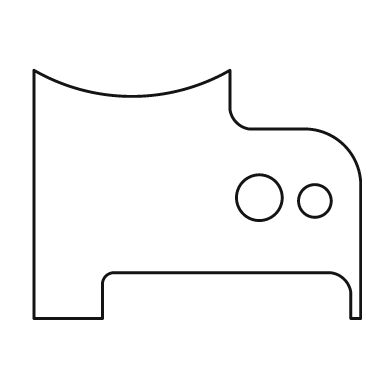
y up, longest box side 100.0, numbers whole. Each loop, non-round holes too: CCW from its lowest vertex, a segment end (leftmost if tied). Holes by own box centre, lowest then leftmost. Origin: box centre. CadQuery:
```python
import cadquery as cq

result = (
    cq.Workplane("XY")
    .moveTo(-50.0, -38.0)
    .lineTo(-29.0, -38.0)
    .lineTo(-29.0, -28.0)
    .threePointArc((-28.0, -25.0), (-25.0, -24.0))
    .lineTo(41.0, -24.0)
    .threePointArc((45.0, -26.0), (47.0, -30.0))
    .lineTo(47.0, -38.0)
    .lineTo(50.0, -38.0)
    .lineTo(50.0, 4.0)
    .threePointArc((45.0, 15.0), (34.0, 20.0))
    .lineTo(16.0, 20.0)
    .threePointArc((12.0, 22.0), (10.0, 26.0))
    .lineTo(10.0, 38.0)
    .threePointArc((-20.0, 30.0), (-50.0, 38.0))
    .close()
    .moveTo(36.0, -2.0)
    .circle(5.0)
    .moveTo(19.0, -1.0)
    .circle(7.0)
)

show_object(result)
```